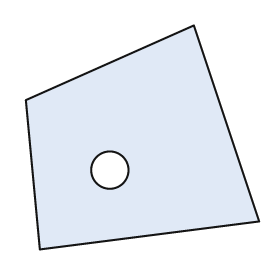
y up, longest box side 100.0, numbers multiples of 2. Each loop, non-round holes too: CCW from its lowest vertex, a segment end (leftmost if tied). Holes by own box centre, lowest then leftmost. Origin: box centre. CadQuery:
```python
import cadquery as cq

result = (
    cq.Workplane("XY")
    .moveTo(-44.0, -48.0)
    .lineTo(50.0, -36.0)
    .lineTo(22.0, 48.0)
    .lineTo(-50.0, 16.0)
    .close()
    .moveTo(-14.0, -14.0)
    .circle(8.0)
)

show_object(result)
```